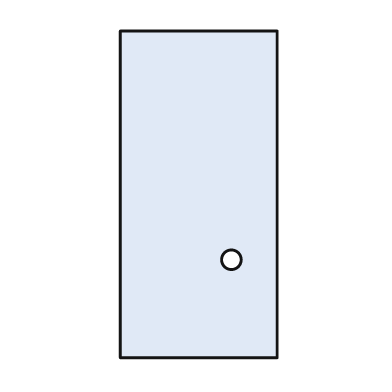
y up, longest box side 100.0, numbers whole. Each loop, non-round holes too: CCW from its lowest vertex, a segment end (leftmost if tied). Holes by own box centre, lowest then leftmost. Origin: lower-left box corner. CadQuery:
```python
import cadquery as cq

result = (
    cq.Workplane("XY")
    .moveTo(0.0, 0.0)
    .lineTo(48.0, 0.0)
    .lineTo(48.0, 100.0)
    .lineTo(0.0, 100.0)
    .close()
    .moveTo(34.0, 30.0)
    .circle(3.0)
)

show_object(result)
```